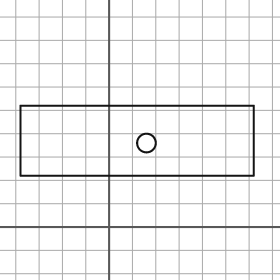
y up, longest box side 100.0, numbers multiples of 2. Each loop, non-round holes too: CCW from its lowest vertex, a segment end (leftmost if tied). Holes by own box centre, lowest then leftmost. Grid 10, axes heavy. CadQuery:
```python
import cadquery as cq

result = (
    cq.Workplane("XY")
    .moveTo(-38.0, 22.0)
    .lineTo(62.0, 22.0)
    .lineTo(62.0, 52.0)
    .lineTo(-38.0, 52.0)
    .close()
    .moveTo(16.0, 36.0)
    .circle(4.0)
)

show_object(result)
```